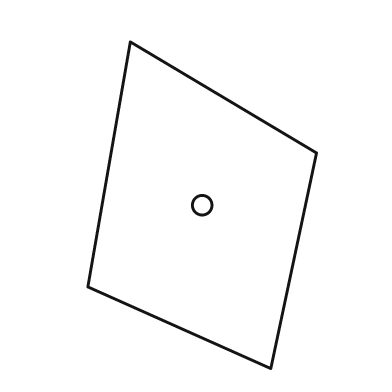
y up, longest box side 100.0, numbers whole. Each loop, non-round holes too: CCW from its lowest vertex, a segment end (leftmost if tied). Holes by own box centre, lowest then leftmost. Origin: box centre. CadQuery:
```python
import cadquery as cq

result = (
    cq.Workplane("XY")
    .moveTo(21.0, -50.0)
    .lineTo(35.0, 16.0)
    .lineTo(-22.0, 50.0)
    .lineTo(-35.0, -25.0)
    .close()
    .moveTo(0.0, 0.0)
    .circle(3.0)
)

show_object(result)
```